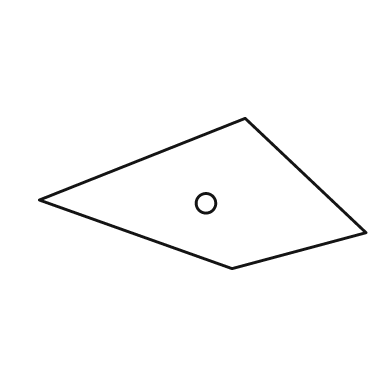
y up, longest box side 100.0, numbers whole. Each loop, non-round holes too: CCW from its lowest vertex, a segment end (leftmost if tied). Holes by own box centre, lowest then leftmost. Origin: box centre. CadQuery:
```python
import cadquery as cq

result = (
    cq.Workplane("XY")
    .moveTo(9.0, -23.0)
    .lineTo(50.0, -12.0)
    .lineTo(13.0, 23.0)
    .lineTo(-50.0, -2.0)
    .close()
    .moveTo(1.0, -3.0)
    .circle(3.0)
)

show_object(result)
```